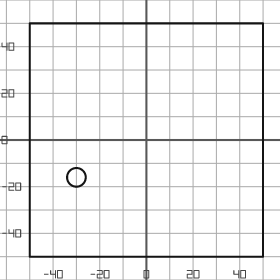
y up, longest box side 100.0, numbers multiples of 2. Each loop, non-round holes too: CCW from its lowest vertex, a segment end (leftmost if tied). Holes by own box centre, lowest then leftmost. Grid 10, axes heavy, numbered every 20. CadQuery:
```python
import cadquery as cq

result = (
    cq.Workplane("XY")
    .moveTo(-50.0, -50.0)
    .lineTo(50.0, -50.0)
    .lineTo(50.0, 50.0)
    .lineTo(-50.0, 50.0)
    .close()
    .moveTo(-30.0, -16.0)
    .circle(4.0)
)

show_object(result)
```